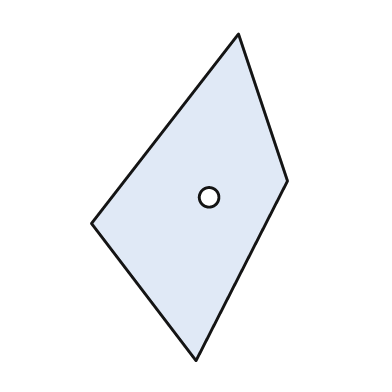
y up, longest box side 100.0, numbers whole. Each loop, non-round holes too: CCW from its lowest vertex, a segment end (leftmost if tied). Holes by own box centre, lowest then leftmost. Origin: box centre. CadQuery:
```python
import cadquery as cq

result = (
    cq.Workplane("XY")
    .moveTo(2.0, -50.0)
    .lineTo(30.0, 5.0)
    .lineTo(15.0, 50.0)
    .lineTo(-30.0, -8.0)
    .close()
    .moveTo(6.0, 0.0)
    .circle(3.0)
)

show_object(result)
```